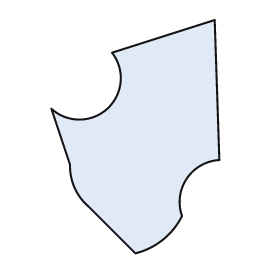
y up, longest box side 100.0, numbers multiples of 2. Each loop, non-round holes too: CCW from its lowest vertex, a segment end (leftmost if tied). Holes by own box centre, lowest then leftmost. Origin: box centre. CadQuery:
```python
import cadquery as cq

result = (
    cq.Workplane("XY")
    .moveTo(0.0, -50.0)
    .threePointArc((12.0, -44.0), (20.0, -34.0))
    .threePointArc((22.0, -18.0), (36.0, -10.0))
    .lineTo(34.0, 50.0)
    .lineTo(-10.0, 36.0)
    .threePointArc((-12.0, 12.0), (-36.0, 12.0))
    .lineTo(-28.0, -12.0)
    .threePointArc((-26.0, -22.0), (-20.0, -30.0))
    .close()
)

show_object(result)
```